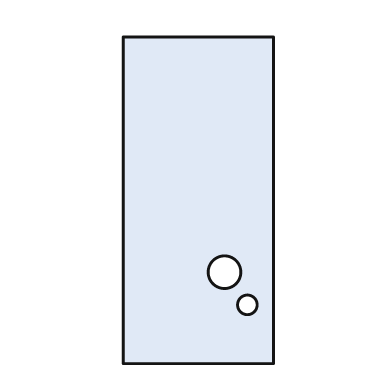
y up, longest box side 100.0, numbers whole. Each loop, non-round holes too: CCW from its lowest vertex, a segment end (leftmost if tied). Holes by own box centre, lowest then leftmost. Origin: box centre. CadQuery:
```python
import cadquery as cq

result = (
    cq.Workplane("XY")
    .moveTo(-23.0, -50.0)
    .lineTo(23.0, -50.0)
    .lineTo(23.0, 50.0)
    .lineTo(-23.0, 50.0)
    .close()
    .moveTo(15.0, -32.0)
    .circle(3.0)
    .moveTo(8.0, -22.0)
    .circle(5.0)
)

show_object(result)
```